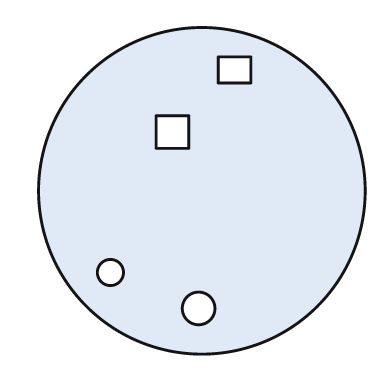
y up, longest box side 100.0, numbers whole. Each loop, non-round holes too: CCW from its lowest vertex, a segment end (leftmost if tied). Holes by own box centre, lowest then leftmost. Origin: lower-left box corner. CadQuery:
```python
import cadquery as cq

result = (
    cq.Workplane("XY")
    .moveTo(50.0, 50.0)
    .circle(50.0)
    .moveTo(49.0, 14.0)
    .circle(5.0)
    .moveTo(22.0, 25.0)
    .circle(4.0)
    .moveTo(36.0, 63.0)
    .lineTo(46.0, 63.0)
    .lineTo(46.0, 73.0)
    .lineTo(36.0, 73.0)
    .close()
    .moveTo(55.0, 83.0)
    .lineTo(65.0, 83.0)
    .lineTo(65.0, 91.0)
    .lineTo(55.0, 91.0)
    .close()
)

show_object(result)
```